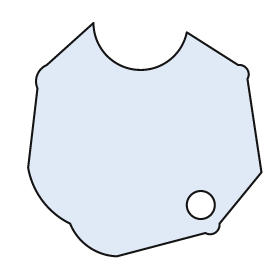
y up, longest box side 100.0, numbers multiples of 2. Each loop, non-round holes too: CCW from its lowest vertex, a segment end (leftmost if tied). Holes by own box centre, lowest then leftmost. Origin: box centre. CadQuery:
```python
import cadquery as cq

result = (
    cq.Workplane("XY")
    .moveTo(-12.0, -50.0)
    .lineTo(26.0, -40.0)
    .threePointArc((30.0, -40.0), (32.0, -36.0))
    .lineTo(50.0, -14.0)
    .lineTo(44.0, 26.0)
    .threePointArc((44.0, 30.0), (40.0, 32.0))
    .lineTo(18.0, 46.0)
    .threePointArc((-4.0, 30.0), (-22.0, 50.0))
    .lineTo(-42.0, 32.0)
    .threePointArc((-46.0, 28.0), (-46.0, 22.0))
    .lineTo(-50.0, -12.0)
    .threePointArc((-44.0, -26.0), (-32.0, -36.0))
    .threePointArc((-24.0, -46.0), (-12.0, -50.0))
    .close()
    .moveTo(24.0, -28.0)
    .circle(6.0)
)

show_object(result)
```